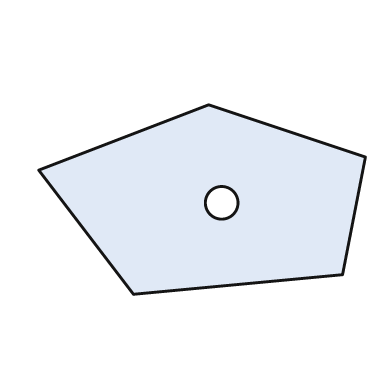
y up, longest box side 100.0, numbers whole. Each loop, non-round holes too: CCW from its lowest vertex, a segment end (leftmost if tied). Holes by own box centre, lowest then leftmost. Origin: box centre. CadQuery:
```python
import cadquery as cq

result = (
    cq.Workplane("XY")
    .moveTo(-21.0, -29.0)
    .lineTo(43.0, -23.0)
    .lineTo(50.0, 13.0)
    .lineTo(2.0, 29.0)
    .lineTo(-50.0, 9.0)
    .close()
    .moveTo(6.0, -1.0)
    .circle(5.0)
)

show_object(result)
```